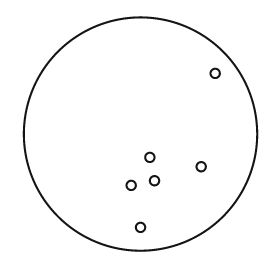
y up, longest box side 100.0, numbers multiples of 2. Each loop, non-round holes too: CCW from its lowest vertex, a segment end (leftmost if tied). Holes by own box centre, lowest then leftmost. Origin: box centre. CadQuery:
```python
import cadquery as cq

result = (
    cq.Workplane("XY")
    .moveTo(0.0, 0.0)
    .circle(50.0)
    .moveTo(0.0, -40.0)
    .circle(2.0)
    .moveTo(-4.0, -22.0)
    .circle(2.0)
    .moveTo(6.0, -20.0)
    .circle(2.0)
    .moveTo(26.0, -14.0)
    .circle(2.0)
    .moveTo(4.0, -10.0)
    .circle(2.0)
    .moveTo(32.0, 26.0)
    .circle(2.0)
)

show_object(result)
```